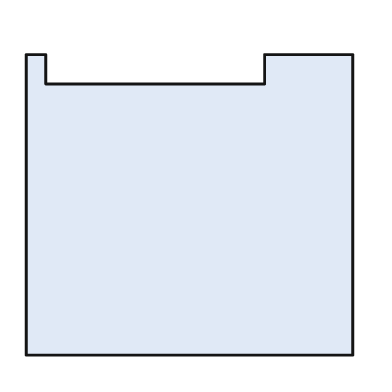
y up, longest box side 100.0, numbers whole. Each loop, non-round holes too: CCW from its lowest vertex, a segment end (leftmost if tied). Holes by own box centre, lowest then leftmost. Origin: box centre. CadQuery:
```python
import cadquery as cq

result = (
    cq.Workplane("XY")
    .moveTo(-50.0, -46.0)
    .lineTo(50.0, -46.0)
    .lineTo(50.0, 46.0)
    .lineTo(23.0, 46.0)
    .lineTo(23.0, 37.0)
    .lineTo(-44.0, 37.0)
    .lineTo(-44.0, 46.0)
    .lineTo(-50.0, 46.0)
    .close()
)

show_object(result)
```